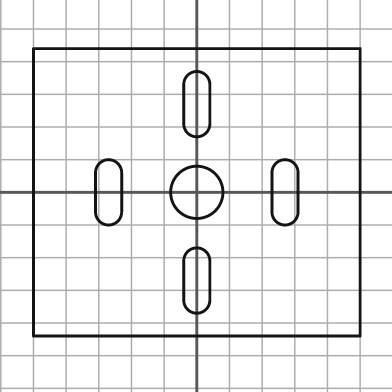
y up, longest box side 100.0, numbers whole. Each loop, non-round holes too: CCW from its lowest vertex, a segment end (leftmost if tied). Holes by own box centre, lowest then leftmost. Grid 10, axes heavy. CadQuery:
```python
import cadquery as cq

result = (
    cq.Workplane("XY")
    .moveTo(-50.0, -44.0)
    .lineTo(50.0, -44.0)
    .lineTo(50.0, 44.0)
    .lineTo(-50.0, 44.0)
    .close()
    .moveTo(-4.0, -33.0)
    .threePointArc((0.0, -37.0), (4.0, -33.0))
    .lineTo(4.0, -21.0)
    .threePointArc((0.0, -17.0), (-4.0, -21.0))
    .close()
    .moveTo(-31.0, -6.0)
    .threePointArc((-27.0, -10.0), (-23.0, -6.0))
    .lineTo(-23.0, 6.0)
    .threePointArc((-27.0, 10.0), (-31.0, 6.0))
    .close()
    .moveTo(0.0, 0.0)
    .circle(8.0)
    .moveTo(23.0, -6.0)
    .threePointArc((27.0, -10.0), (31.0, -6.0))
    .lineTo(31.0, 6.0)
    .threePointArc((27.0, 10.0), (23.0, 6.0))
    .close()
    .moveTo(-4.0, 21.0)
    .threePointArc((0.0, 17.0), (4.0, 21.0))
    .lineTo(4.0, 33.0)
    .threePointArc((0.0, 37.0), (-4.0, 33.0))
    .close()
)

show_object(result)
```